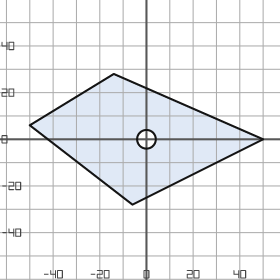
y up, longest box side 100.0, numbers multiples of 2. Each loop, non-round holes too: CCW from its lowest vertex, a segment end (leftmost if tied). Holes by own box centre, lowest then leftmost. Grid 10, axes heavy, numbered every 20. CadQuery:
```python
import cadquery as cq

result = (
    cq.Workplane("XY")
    .moveTo(-6.0, -28.0)
    .lineTo(50.0, 0.0)
    .lineTo(-14.0, 28.0)
    .lineTo(-50.0, 6.0)
    .close()
    .moveTo(0.0, 0.0)
    .circle(4.0)
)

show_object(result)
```